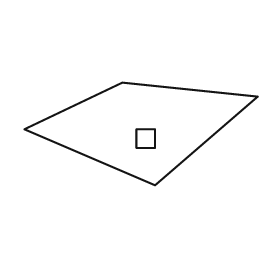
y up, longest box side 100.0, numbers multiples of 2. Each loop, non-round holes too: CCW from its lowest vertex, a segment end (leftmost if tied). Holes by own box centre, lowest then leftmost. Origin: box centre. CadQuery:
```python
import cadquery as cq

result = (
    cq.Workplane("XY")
    .moveTo(6.0, -22.0)
    .lineTo(50.0, 16.0)
    .lineTo(-8.0, 22.0)
    .lineTo(-50.0, 2.0)
    .close()
    .moveTo(-2.0, -6.0)
    .lineTo(6.0, -6.0)
    .lineTo(6.0, 2.0)
    .lineTo(-2.0, 2.0)
    .close()
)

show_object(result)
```